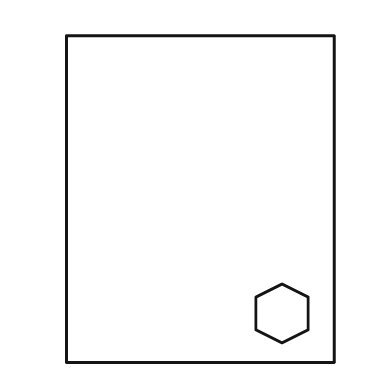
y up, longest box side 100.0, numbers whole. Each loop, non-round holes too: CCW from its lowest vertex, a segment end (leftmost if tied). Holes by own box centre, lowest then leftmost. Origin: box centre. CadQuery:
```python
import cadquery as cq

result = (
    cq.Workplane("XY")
    .moveTo(-41.0, -50.0)
    .lineTo(41.0, -50.0)
    .lineTo(41.0, 50.0)
    .lineTo(-41.0, 50.0)
    .close()
    .moveTo(25.0, -44.0)
    .lineTo(33.0, -40.0)
    .lineTo(33.0, -30.0)
    .lineTo(25.0, -26.0)
    .lineTo(17.0, -30.0)
    .lineTo(17.0, -40.0)
    .close()
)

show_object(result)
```